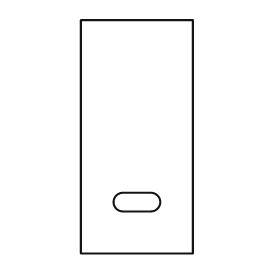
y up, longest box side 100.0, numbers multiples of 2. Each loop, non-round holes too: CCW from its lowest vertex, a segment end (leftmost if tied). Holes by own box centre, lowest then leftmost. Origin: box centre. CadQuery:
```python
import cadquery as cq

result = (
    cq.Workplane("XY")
    .moveTo(-24.0, -50.0)
    .lineTo(24.0, -50.0)
    .lineTo(24.0, 50.0)
    .lineTo(-24.0, 50.0)
    .close()
    .moveTo(-6.0, -32.0)
    .lineTo(6.0, -32.0)
    .threePointArc((10.0, -28.0), (6.0, -24.0))
    .lineTo(-6.0, -24.0)
    .threePointArc((-10.0, -28.0), (-6.0, -32.0))
    .close()
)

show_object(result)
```